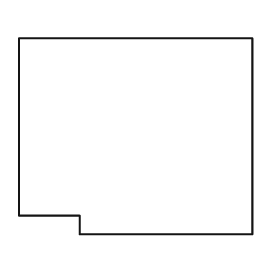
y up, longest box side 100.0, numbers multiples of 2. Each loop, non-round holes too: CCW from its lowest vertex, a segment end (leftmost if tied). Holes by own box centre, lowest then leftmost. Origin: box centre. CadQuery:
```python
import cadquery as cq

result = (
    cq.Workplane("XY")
    .moveTo(-24.0, -42.0)
    .lineTo(50.0, -42.0)
    .lineTo(50.0, 42.0)
    .lineTo(-50.0, 42.0)
    .lineTo(-50.0, -34.0)
    .lineTo(-24.0, -34.0)
    .close()
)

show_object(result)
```